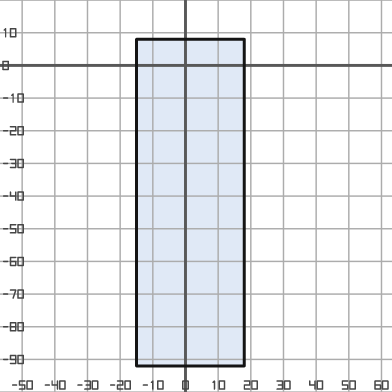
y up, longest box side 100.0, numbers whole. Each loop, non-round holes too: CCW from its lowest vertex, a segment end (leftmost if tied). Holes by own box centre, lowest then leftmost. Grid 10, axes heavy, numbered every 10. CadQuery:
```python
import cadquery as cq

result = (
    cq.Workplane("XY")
    .moveTo(-15.0, -92.0)
    .lineTo(18.0, -92.0)
    .lineTo(18.0, 8.0)
    .lineTo(-15.0, 8.0)
    .close()
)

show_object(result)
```